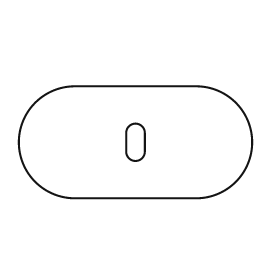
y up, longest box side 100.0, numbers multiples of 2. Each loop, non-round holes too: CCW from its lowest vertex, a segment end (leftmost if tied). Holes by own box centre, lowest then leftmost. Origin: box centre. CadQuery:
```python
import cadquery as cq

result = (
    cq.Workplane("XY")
    .moveTo(-26.0, -24.0)
    .lineTo(26.0, -24.0)
    .threePointArc((50.0, 0.0), (26.0, 24.0))
    .lineTo(-26.0, 24.0)
    .threePointArc((-50.0, 0.0), (-26.0, -24.0))
    .close()
    .moveTo(-4.0, -4.0)
    .threePointArc((0.0, -8.0), (4.0, -4.0))
    .lineTo(4.0, 4.0)
    .threePointArc((0.0, 8.0), (-4.0, 4.0))
    .close()
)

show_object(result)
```